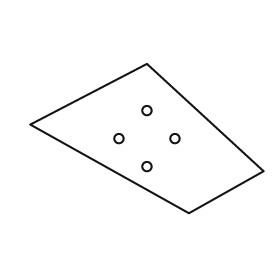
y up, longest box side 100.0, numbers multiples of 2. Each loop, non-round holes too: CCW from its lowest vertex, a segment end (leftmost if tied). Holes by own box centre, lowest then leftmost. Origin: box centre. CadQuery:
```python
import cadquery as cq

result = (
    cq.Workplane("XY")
    .moveTo(18.0, -32.0)
    .lineTo(50.0, -14.0)
    .lineTo(0.0, 32.0)
    .lineTo(-50.0, 6.0)
    .close()
    .moveTo(0.0, -12.0)
    .circle(2.0)
    .moveTo(-12.0, 0.0)
    .circle(2.0)
    .moveTo(12.0, 0.0)
    .circle(2.0)
    .moveTo(0.0, 12.0)
    .circle(2.0)
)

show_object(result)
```